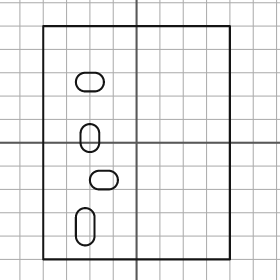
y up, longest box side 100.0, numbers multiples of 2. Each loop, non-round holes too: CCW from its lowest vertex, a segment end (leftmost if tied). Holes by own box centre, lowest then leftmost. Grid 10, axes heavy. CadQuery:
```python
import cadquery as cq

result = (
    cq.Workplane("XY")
    .moveTo(-40.0, -50.0)
    .lineTo(40.0, -50.0)
    .lineTo(40.0, 50.0)
    .lineTo(-40.0, 50.0)
    .close()
    .moveTo(-26.0, -40.0)
    .threePointArc((-22.0, -44.0), (-18.0, -40.0))
    .lineTo(-18.0, -32.0)
    .threePointArc((-22.0, -28.0), (-26.0, -32.0))
    .close()
    .moveTo(-16.0, -20.0)
    .lineTo(-12.0, -20.0)
    .threePointArc((-8.0, -16.0), (-12.0, -12.0))
    .lineTo(-16.0, -12.0)
    .threePointArc((-20.0, -16.0), (-16.0, -20.0))
    .close()
    .moveTo(-24.0, 0.0)
    .threePointArc((-20.0, -4.0), (-16.0, 0.0))
    .lineTo(-16.0, 4.0)
    .threePointArc((-20.0, 8.0), (-24.0, 4.0))
    .close()
    .moveTo(-22.0, 22.0)
    .lineTo(-18.0, 22.0)
    .threePointArc((-14.0, 26.0), (-18.0, 30.0))
    .lineTo(-22.0, 30.0)
    .threePointArc((-26.0, 26.0), (-22.0, 22.0))
    .close()
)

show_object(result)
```